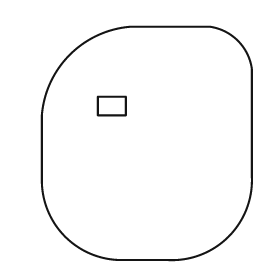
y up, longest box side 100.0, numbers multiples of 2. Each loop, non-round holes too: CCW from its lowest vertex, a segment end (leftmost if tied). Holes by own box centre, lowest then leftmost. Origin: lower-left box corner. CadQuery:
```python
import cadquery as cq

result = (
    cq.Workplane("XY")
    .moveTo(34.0, 0.0)
    .lineTo(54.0, 0.0)
    .threePointArc((80.0, 10.0), (90.0, 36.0))
    .lineTo(90.0, 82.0)
    .threePointArc((84.0, 94.0), (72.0, 100.0))
    .lineTo(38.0, 100.0)
    .threePointArc((12.0, 88.0), (0.0, 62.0))
    .lineTo(0.0, 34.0)
    .threePointArc((10.0, 10.0), (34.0, 0.0))
    .close()
    .moveTo(24.0, 62.0)
    .lineTo(36.0, 62.0)
    .lineTo(36.0, 70.0)
    .lineTo(24.0, 70.0)
    .close()
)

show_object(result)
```